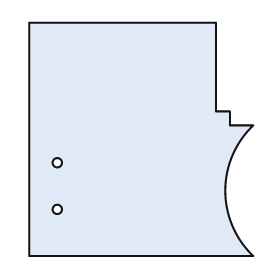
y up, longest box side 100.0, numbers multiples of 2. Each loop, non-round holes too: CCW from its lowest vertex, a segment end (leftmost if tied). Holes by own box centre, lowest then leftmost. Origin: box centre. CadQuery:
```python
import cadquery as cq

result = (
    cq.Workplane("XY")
    .moveTo(-48.0, -50.0)
    .lineTo(48.0, -50.0)
    .threePointArc((36.0, -22.0), (48.0, 6.0))
    .lineTo(38.0, 6.0)
    .lineTo(38.0, 12.0)
    .lineTo(32.0, 12.0)
    .lineTo(32.0, 50.0)
    .lineTo(-48.0, 50.0)
    .close()
    .moveTo(-36.0, -30.0)
    .circle(2.0)
    .moveTo(-36.0, -10.0)
    .circle(2.0)
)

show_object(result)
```